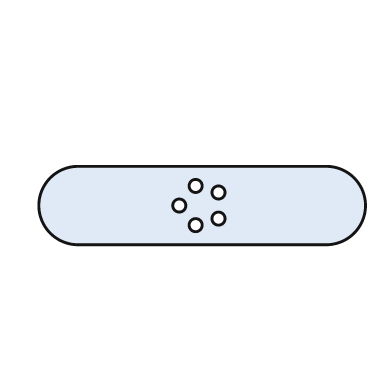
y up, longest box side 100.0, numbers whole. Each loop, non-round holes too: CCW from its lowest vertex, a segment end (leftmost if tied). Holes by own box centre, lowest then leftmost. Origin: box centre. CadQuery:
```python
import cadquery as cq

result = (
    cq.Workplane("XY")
    .moveTo(-38.0, -12.0)
    .lineTo(38.0, -12.0)
    .threePointArc((50.0, 0.0), (38.0, 12.0))
    .lineTo(-38.0, 12.0)
    .threePointArc((-50.0, 0.0), (-38.0, -12.0))
    .close()
    .moveTo(-2.0, -6.0)
    .circle(2.0)
    .moveTo(5.0, -4.0)
    .circle(2.0)
    .moveTo(-7.0, 0.0)
    .circle(2.0)
    .moveTo(5.0, 4.0)
    .circle(2.0)
    .moveTo(-2.0, 6.0)
    .circle(2.0)
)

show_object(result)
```